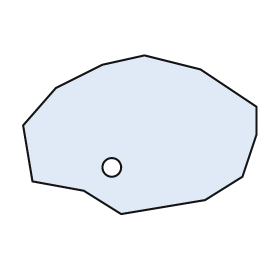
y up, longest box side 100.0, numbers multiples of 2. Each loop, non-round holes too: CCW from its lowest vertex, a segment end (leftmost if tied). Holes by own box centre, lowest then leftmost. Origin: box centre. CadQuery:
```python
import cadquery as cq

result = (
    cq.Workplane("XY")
    .moveTo(-8.0, -34.0)
    .lineTo(28.0, -28.0)
    .lineTo(44.0, -18.0)
    .lineTo(50.0, 0.0)
    .lineTo(50.0, 12.0)
    .lineTo(26.0, 28.0)
    .lineTo(2.0, 34.0)
    .lineTo(-16.0, 30.0)
    .lineTo(-36.0, 20.0)
    .lineTo(-50.0, 4.0)
    .lineTo(-46.0, -20.0)
    .lineTo(-24.0, -24.0)
    .close()
    .moveTo(-12.0, -14.0)
    .circle(4.0)
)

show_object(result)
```